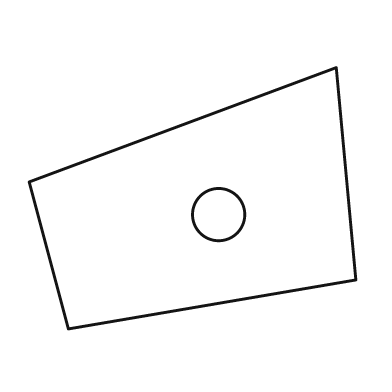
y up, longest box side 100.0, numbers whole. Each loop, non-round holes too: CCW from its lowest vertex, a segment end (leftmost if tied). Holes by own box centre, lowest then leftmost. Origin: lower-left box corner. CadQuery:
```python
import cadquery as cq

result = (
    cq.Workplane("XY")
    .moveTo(12.0, 0.0)
    .lineTo(100.0, 15.0)
    .lineTo(94.0, 80.0)
    .lineTo(0.0, 45.0)
    .close()
    .moveTo(58.0, 35.0)
    .circle(8.0)
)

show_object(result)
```